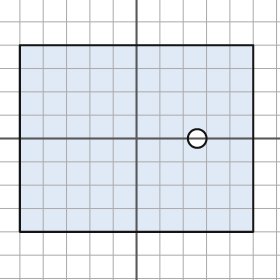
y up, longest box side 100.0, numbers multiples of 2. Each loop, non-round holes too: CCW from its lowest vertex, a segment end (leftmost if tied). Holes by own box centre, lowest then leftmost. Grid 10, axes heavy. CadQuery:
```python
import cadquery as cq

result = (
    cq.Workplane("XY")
    .moveTo(-50.0, -40.0)
    .lineTo(50.0, -40.0)
    .lineTo(50.0, 40.0)
    .lineTo(-50.0, 40.0)
    .close()
    .moveTo(26.0, 0.0)
    .circle(4.0)
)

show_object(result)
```